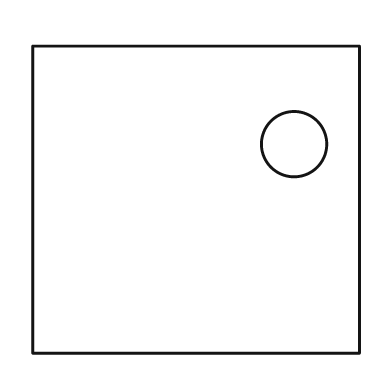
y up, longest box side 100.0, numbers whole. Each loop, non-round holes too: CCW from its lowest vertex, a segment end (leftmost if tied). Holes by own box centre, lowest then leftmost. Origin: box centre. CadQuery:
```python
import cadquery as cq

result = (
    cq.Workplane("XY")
    .moveTo(-50.0, -47.0)
    .lineTo(50.0, -47.0)
    .lineTo(50.0, 47.0)
    .lineTo(-50.0, 47.0)
    .close()
    .moveTo(30.0, 17.0)
    .circle(10.0)
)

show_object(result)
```